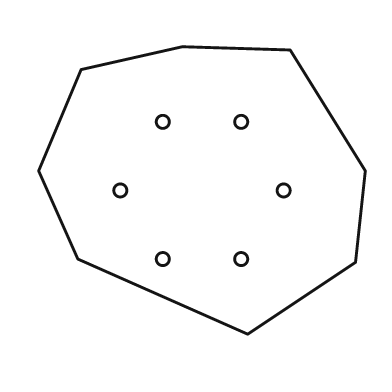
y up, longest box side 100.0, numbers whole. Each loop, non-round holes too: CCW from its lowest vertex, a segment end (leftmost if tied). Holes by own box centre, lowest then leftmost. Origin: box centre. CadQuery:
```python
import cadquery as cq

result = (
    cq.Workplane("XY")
    .moveTo(14.0, -44.0)
    .lineTo(47.0, -22.0)
    .lineTo(50.0, 6.0)
    .lineTo(27.0, 43.0)
    .lineTo(-6.0, 44.0)
    .lineTo(-37.0, 37.0)
    .lineTo(-50.0, 6.0)
    .lineTo(-38.0, -21.0)
    .close()
    .moveTo(-12.0, -21.0)
    .circle(2.0)
    .moveTo(12.0, -21.0)
    .circle(2.0)
    .moveTo(-25.0, 0.0)
    .circle(2.0)
    .moveTo(25.0, 0.0)
    .circle(2.0)
    .moveTo(-12.0, 21.0)
    .circle(2.0)
    .moveTo(12.0, 21.0)
    .circle(2.0)
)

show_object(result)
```